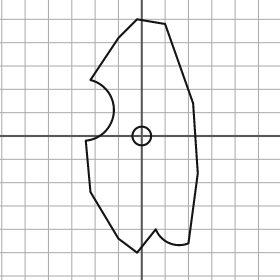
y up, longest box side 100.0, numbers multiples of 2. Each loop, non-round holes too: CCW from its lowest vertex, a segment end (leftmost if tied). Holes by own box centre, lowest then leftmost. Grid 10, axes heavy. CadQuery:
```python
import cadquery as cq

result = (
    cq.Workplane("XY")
    .moveTo(-2.0, -50.0)
    .lineTo(6.0, -40.0)
    .threePointArc((12.0, -46.0), (20.0, -46.0))
    .lineTo(24.0, -16.0)
    .lineTo(22.0, 14.0)
    .lineTo(10.0, 48.0)
    .lineTo(-2.0, 50.0)
    .lineTo(-10.0, 42.0)
    .lineTo(-22.0, 24.0)
    .threePointArc((-12.0, 10.0), (-24.0, -2.0))
    .lineTo(-22.0, -24.0)
    .lineTo(-10.0, -44.0)
    .close()
    .moveTo(0.0, 0.0)
    .circle(4.0)
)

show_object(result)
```